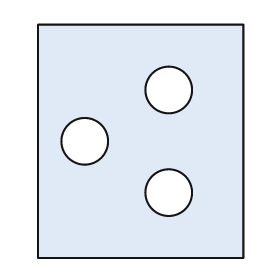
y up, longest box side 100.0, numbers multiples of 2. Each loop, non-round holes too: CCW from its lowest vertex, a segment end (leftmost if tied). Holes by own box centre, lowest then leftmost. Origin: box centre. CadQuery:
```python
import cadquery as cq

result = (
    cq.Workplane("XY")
    .moveTo(-44.0, -50.0)
    .lineTo(44.0, -50.0)
    .lineTo(44.0, 50.0)
    .lineTo(-44.0, 50.0)
    .close()
    .moveTo(12.0, -22.0)
    .circle(10.0)
    .moveTo(-24.0, 0.0)
    .circle(10.0)
    .moveTo(12.0, 22.0)
    .circle(10.0)
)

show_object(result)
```